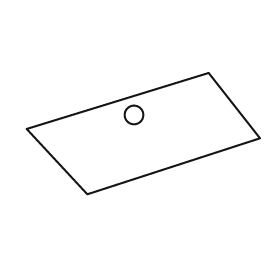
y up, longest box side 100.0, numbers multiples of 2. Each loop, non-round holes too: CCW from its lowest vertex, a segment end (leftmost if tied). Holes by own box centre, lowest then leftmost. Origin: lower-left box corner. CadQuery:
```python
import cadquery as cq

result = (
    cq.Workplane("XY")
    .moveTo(26.0, 0.0)
    .lineTo(100.0, 24.0)
    .lineTo(78.0, 52.0)
    .lineTo(0.0, 28.0)
    .close()
    .moveTo(46.0, 34.0)
    .circle(4.0)
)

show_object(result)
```